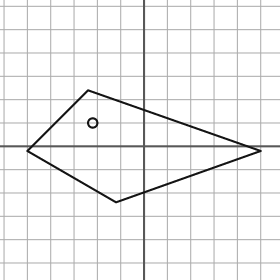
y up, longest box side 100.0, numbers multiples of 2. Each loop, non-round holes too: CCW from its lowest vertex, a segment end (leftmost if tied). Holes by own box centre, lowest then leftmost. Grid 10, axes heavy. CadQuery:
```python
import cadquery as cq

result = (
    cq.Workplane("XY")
    .moveTo(-12.0, -24.0)
    .lineTo(50.0, -2.0)
    .lineTo(-24.0, 24.0)
    .lineTo(-50.0, -2.0)
    .close()
    .moveTo(-22.0, 10.0)
    .circle(2.0)
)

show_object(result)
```